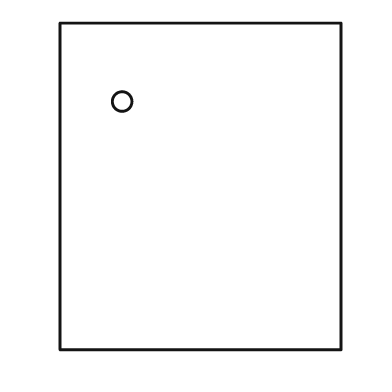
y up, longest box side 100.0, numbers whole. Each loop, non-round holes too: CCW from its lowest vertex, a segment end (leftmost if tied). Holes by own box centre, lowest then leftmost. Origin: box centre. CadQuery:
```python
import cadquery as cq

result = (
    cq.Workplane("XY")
    .moveTo(-43.0, -50.0)
    .lineTo(43.0, -50.0)
    .lineTo(43.0, 50.0)
    .lineTo(-43.0, 50.0)
    .close()
    .moveTo(-24.0, 26.0)
    .circle(3.0)
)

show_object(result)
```